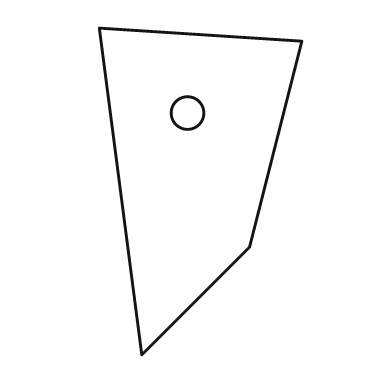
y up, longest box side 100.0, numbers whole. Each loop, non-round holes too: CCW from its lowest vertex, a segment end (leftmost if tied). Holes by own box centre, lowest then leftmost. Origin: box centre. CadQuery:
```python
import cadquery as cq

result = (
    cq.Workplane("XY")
    .moveTo(-18.0, -50.0)
    .lineTo(15.0, -17.0)
    .lineTo(31.0, 46.0)
    .lineTo(-31.0, 50.0)
    .close()
    .moveTo(-4.0, 24.0)
    .circle(5.0)
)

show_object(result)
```